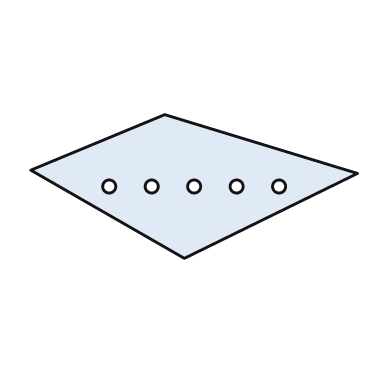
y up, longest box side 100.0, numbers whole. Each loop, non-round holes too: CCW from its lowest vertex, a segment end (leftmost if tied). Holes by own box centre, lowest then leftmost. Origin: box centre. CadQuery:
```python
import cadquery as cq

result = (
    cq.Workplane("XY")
    .moveTo(-3.0, -22.0)
    .lineTo(50.0, 4.0)
    .lineTo(-9.0, 22.0)
    .lineTo(-50.0, 5.0)
    .close()
    .moveTo(-26.0, 0.0)
    .circle(2.0)
    .moveTo(-13.0, 0.0)
    .circle(2.0)
    .moveTo(0.0, 0.0)
    .circle(2.0)
    .moveTo(13.0, 0.0)
    .circle(2.0)
    .moveTo(26.0, 0.0)
    .circle(2.0)
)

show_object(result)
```